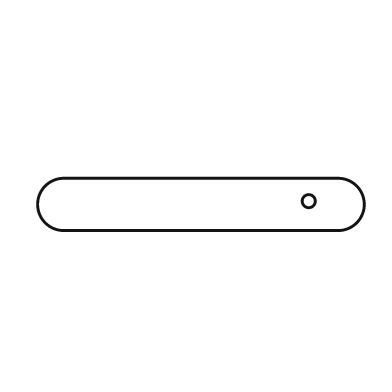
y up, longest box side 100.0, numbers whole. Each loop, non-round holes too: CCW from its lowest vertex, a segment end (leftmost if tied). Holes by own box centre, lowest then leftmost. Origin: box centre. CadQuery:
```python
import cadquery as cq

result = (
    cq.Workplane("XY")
    .moveTo(-42.0, -8.0)
    .lineTo(42.0, -8.0)
    .threePointArc((50.0, 0.0), (42.0, 8.0))
    .lineTo(-42.0, 8.0)
    .threePointArc((-50.0, 0.0), (-42.0, -8.0))
    .close()
    .moveTo(33.0, 1.0)
    .circle(2.0)
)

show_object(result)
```